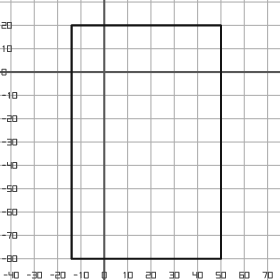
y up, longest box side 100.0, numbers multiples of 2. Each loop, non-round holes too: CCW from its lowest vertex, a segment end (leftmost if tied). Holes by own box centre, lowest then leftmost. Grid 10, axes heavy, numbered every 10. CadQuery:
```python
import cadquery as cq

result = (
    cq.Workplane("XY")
    .moveTo(-14.0, -80.0)
    .lineTo(50.0, -80.0)
    .lineTo(50.0, 20.0)
    .lineTo(-14.0, 20.0)
    .close()
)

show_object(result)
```